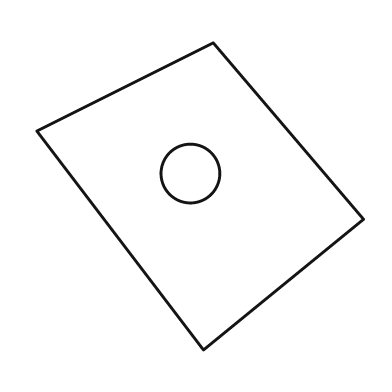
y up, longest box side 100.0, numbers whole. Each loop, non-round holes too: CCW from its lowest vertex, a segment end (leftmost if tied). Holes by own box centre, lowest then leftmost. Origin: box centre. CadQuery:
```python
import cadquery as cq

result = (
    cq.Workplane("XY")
    .moveTo(1.0, -47.0)
    .lineTo(50.0, -7.0)
    .lineTo(4.0, 47.0)
    .lineTo(-50.0, 20.0)
    .close()
    .moveTo(-3.0, 7.0)
    .circle(9.0)
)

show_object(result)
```